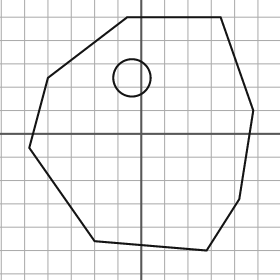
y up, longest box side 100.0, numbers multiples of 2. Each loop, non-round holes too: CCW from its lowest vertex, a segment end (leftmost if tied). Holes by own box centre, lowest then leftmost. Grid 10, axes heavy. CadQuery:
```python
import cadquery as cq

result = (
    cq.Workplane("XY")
    .moveTo(28.0, -50.0)
    .lineTo(42.0, -28.0)
    .lineTo(48.0, 10.0)
    .lineTo(34.0, 50.0)
    .lineTo(-6.0, 50.0)
    .lineTo(-40.0, 24.0)
    .lineTo(-48.0, -6.0)
    .lineTo(-20.0, -46.0)
    .close()
    .moveTo(-4.0, 24.0)
    .circle(8.0)
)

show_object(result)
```